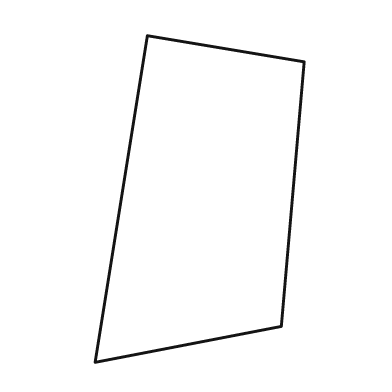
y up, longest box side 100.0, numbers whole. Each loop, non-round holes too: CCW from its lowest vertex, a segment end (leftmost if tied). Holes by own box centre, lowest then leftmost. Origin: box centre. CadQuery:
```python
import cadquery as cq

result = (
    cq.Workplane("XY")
    .moveTo(-32.0, -50.0)
    .lineTo(25.0, -39.0)
    .lineTo(32.0, 42.0)
    .lineTo(-16.0, 50.0)
    .close()
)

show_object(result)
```